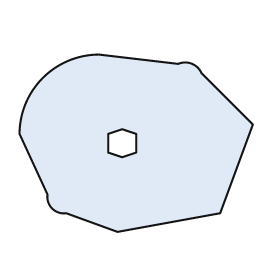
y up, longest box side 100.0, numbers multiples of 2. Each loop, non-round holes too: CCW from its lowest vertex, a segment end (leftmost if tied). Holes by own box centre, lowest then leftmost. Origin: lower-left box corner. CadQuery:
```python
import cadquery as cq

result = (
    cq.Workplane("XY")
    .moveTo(42.0, 0.0)
    .lineTo(86.0, 8.0)
    .lineTo(100.0, 46.0)
    .lineTo(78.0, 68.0)
    .threePointArc((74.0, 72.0), (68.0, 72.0))
    .lineTo(34.0, 76.0)
    .threePointArc((10.0, 66.0), (0.0, 42.0))
    .lineTo(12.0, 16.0)
    .threePointArc((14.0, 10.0), (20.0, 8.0))
    .close()
    .moveTo(44.0, 32.0)
    .lineTo(50.0, 34.0)
    .lineTo(50.0, 42.0)
    .lineTo(44.0, 44.0)
    .lineTo(38.0, 42.0)
    .lineTo(38.0, 34.0)
    .close()
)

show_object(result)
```